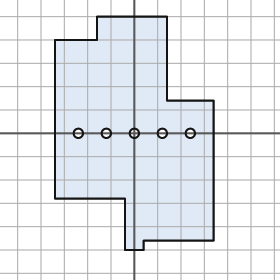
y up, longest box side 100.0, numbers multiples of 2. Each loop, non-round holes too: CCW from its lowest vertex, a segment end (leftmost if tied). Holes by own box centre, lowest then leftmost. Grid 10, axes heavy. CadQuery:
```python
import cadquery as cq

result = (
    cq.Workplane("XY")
    .moveTo(-4.0, -50.0)
    .lineTo(4.0, -50.0)
    .lineTo(4.0, -46.0)
    .lineTo(34.0, -46.0)
    .lineTo(34.0, 14.0)
    .lineTo(14.0, 14.0)
    .lineTo(14.0, 50.0)
    .lineTo(-16.0, 50.0)
    .lineTo(-16.0, 40.0)
    .lineTo(-34.0, 40.0)
    .lineTo(-34.0, -28.0)
    .lineTo(-4.0, -28.0)
    .close()
    .moveTo(-24.0, 0.0)
    .circle(2.0)
    .moveTo(-12.0, 0.0)
    .circle(2.0)
    .moveTo(0.0, 0.0)
    .circle(2.0)
    .moveTo(12.0, 0.0)
    .circle(2.0)
    .moveTo(24.0, 0.0)
    .circle(2.0)
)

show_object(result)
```